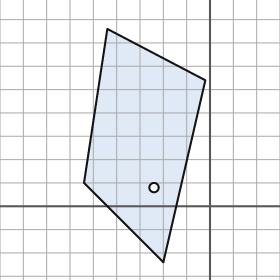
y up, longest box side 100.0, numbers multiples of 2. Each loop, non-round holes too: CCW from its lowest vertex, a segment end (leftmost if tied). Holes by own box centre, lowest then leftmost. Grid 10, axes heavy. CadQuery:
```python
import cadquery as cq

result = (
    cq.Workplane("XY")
    .moveTo(-20.0, -24.0)
    .lineTo(-2.0, 54.0)
    .lineTo(-44.0, 76.0)
    .lineTo(-54.0, 10.0)
    .close()
    .moveTo(-24.0, 8.0)
    .circle(2.0)
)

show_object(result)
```